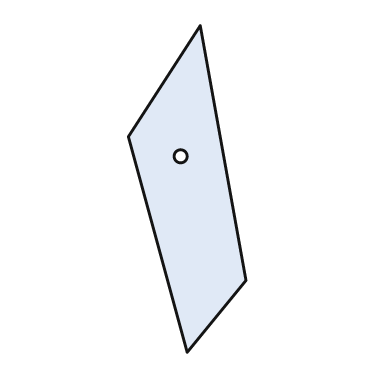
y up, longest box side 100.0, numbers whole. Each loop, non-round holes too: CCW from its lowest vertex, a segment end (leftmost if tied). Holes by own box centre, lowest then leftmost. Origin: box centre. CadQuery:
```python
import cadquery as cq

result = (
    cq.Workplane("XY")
    .moveTo(0.0, -50.0)
    .lineTo(18.0, -28.0)
    .lineTo(4.0, 50.0)
    .lineTo(-18.0, 16.0)
    .close()
    .moveTo(-2.0, 10.0)
    .circle(2.0)
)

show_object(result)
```